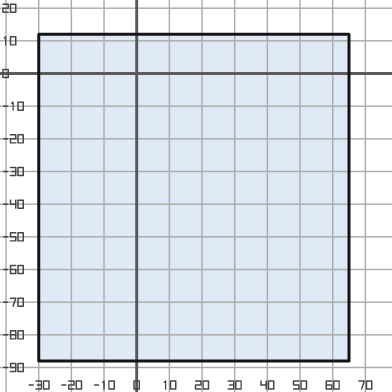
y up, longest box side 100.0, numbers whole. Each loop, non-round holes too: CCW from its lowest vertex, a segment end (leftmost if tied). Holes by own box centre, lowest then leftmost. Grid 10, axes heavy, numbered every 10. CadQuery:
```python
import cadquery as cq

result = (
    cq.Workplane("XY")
    .moveTo(-30.0, -88.0)
    .lineTo(65.0, -88.0)
    .lineTo(65.0, 12.0)
    .lineTo(-30.0, 12.0)
    .close()
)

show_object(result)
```